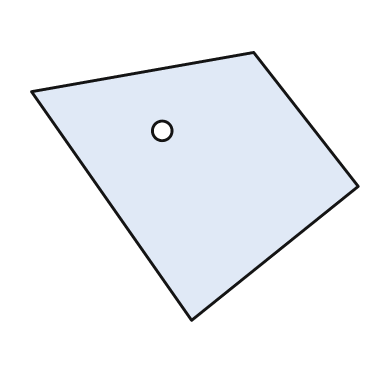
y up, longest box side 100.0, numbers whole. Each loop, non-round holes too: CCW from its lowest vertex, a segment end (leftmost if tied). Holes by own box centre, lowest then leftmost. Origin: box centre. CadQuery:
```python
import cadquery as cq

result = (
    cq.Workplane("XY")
    .moveTo(-1.0, -41.0)
    .lineTo(50.0, 0.0)
    .lineTo(18.0, 41.0)
    .lineTo(-50.0, 29.0)
    .close()
    .moveTo(-10.0, 17.0)
    .circle(3.0)
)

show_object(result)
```